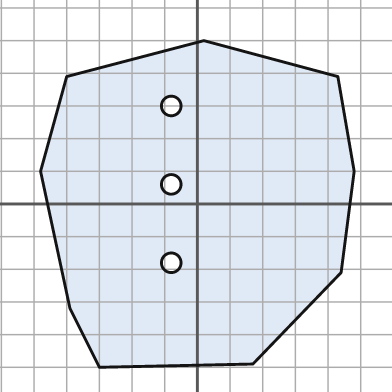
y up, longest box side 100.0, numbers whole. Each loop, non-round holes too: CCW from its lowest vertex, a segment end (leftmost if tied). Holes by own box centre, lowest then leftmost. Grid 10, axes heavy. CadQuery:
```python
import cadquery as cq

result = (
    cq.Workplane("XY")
    .moveTo(-30.0, -50.0)
    .lineTo(17.0, -49.0)
    .lineTo(44.0, -21.0)
    .lineTo(48.0, 10.0)
    .lineTo(43.0, 39.0)
    .lineTo(2.0, 50.0)
    .lineTo(-40.0, 39.0)
    .lineTo(-48.0, 10.0)
    .lineTo(-39.0, -32.0)
    .close()
    .moveTo(-8.0, -18.0)
    .circle(3.0)
    .moveTo(-8.0, 6.0)
    .circle(3.0)
    .moveTo(-8.0, 30.0)
    .circle(3.0)
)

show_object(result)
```